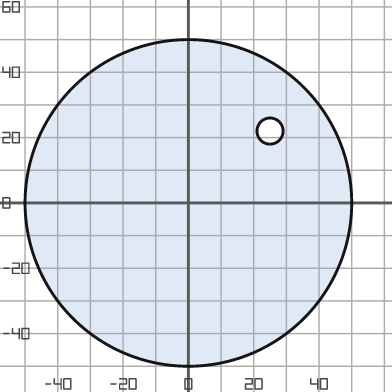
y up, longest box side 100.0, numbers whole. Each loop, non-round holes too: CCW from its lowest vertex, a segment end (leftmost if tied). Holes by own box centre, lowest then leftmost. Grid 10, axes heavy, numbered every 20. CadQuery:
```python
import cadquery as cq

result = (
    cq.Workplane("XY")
    .moveTo(0.0, 0.0)
    .circle(50.0)
    .moveTo(25.0, 22.0)
    .circle(4.0)
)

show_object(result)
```